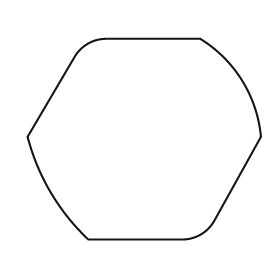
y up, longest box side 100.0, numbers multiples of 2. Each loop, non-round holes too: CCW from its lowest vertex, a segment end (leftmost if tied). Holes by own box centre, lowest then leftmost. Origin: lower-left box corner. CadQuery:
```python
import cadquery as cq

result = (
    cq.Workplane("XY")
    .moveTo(26.0, 0.0)
    .lineTo(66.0, 0.0)
    .threePointArc((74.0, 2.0), (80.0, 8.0))
    .lineTo(100.0, 44.0)
    .threePointArc((92.0, 68.0), (74.0, 86.0))
    .lineTo(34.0, 86.0)
    .threePointArc((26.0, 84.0), (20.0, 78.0))
    .lineTo(0.0, 44.0)
    .threePointArc((10.0, 20.0), (26.0, 0.0))
    .close()
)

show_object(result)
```